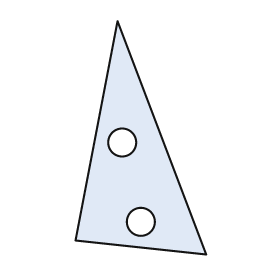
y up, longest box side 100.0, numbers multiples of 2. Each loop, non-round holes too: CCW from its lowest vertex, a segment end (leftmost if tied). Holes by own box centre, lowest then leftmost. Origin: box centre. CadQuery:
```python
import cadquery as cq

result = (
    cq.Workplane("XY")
    .moveTo(28.0, -50.0)
    .lineTo(-10.0, 50.0)
    .lineTo(-28.0, -44.0)
    .close()
    .moveTo(0.0, -36.0)
    .circle(6.0)
    .moveTo(-8.0, -2.0)
    .circle(6.0)
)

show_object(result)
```